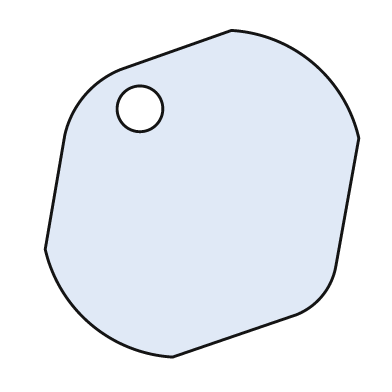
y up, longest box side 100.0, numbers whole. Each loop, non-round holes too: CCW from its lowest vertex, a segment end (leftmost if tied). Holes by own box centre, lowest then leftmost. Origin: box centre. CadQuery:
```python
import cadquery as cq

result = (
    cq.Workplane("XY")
    .moveTo(-9.0, -50.0)
    .lineTo(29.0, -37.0)
    .threePointArc((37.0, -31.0), (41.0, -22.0))
    .lineTo(48.0, 17.0)
    .threePointArc((34.0, 40.0), (9.0, 50.0))
    .lineTo(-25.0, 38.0)
    .threePointArc((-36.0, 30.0), (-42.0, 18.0))
    .lineTo(-48.0, -17.0)
    .threePointArc((-34.0, -40.0), (-9.0, -50.0))
    .close()
    .moveTo(-19.0, 26.0)
    .circle(7.0)
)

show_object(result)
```